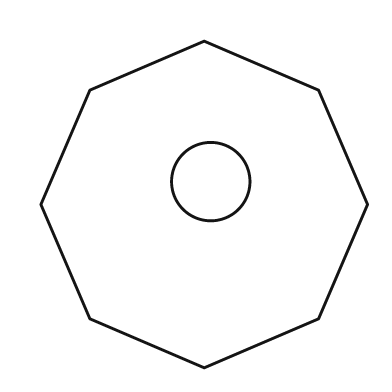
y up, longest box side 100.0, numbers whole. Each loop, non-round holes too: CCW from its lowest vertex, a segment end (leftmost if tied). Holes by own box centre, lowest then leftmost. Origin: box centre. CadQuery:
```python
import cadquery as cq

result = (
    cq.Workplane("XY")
    .moveTo(0.0, -50.0)
    .lineTo(35.0, -35.0)
    .lineTo(50.0, 0.0)
    .lineTo(35.0, 35.0)
    .lineTo(0.0, 50.0)
    .lineTo(-35.0, 35.0)
    .lineTo(-50.0, 0.0)
    .lineTo(-35.0, -35.0)
    .close()
    .moveTo(2.0, 7.0)
    .circle(12.0)
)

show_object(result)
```